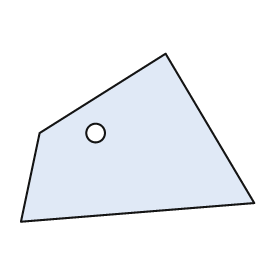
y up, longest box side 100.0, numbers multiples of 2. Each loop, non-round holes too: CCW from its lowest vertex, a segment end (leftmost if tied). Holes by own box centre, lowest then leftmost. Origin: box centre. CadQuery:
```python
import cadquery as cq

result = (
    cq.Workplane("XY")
    .moveTo(-50.0, -36.0)
    .lineTo(50.0, -28.0)
    .lineTo(12.0, 36.0)
    .lineTo(-42.0, 2.0)
    .close()
    .moveTo(-18.0, 2.0)
    .circle(4.0)
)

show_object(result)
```